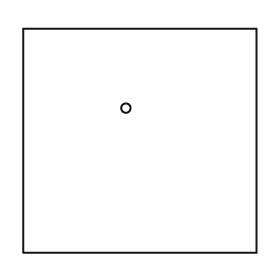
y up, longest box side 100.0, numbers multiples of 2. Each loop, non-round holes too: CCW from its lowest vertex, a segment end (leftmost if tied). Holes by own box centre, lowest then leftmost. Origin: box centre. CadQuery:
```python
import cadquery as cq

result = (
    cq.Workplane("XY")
    .moveTo(-50.0, -48.0)
    .lineTo(50.0, -48.0)
    .lineTo(50.0, 48.0)
    .lineTo(-50.0, 48.0)
    .close()
    .moveTo(-6.0, 14.0)
    .circle(2.0)
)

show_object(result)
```